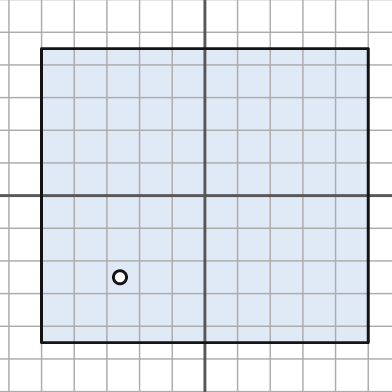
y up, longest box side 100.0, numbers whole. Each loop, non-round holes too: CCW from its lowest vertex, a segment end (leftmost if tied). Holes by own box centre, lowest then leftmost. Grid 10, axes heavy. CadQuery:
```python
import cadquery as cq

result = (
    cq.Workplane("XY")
    .moveTo(-50.0, -45.0)
    .lineTo(50.0, -45.0)
    .lineTo(50.0, 45.0)
    .lineTo(-50.0, 45.0)
    .close()
    .moveTo(-26.0, -25.0)
    .circle(2.0)
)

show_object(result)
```